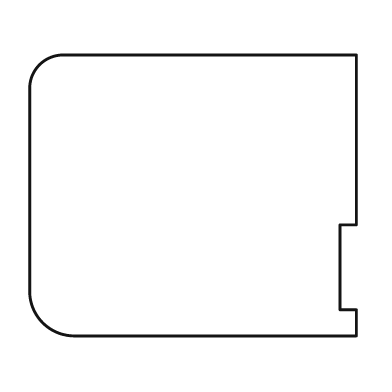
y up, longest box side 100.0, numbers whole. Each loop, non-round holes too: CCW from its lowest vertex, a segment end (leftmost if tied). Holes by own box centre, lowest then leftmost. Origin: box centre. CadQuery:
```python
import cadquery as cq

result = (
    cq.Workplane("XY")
    .moveTo(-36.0, -43.0)
    .lineTo(50.0, -43.0)
    .lineTo(50.0, -35.0)
    .lineTo(45.0, -35.0)
    .lineTo(45.0, -9.0)
    .lineTo(50.0, -9.0)
    .lineTo(50.0, 43.0)
    .lineTo(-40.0, 43.0)
    .threePointArc((-47.0, 40.0), (-50.0, 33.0))
    .lineTo(-50.0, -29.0)
    .threePointArc((-46.0, -39.0), (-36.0, -43.0))
    .close()
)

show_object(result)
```